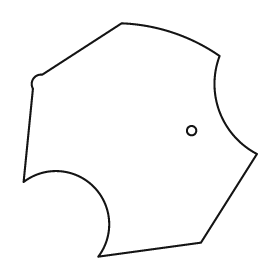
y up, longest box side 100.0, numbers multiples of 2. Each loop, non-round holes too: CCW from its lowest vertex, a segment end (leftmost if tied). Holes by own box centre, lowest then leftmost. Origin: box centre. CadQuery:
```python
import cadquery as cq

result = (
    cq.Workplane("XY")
    .moveTo(-18.0, -50.0)
    .lineTo(26.0, -44.0)
    .lineTo(50.0, -6.0)
    .threePointArc((34.0, 12.0), (34.0, 36.0))
    .threePointArc((14.0, 46.0), (-8.0, 50.0))
    .lineTo(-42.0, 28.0)
    .threePointArc((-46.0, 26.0), (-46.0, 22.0))
    .lineTo(-50.0, -18.0)
    .threePointArc((-20.0, -20.0), (-18.0, -50.0))
    .close()
    .moveTo(22.0, 4.0)
    .circle(2.0)
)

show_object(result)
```